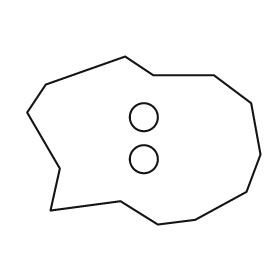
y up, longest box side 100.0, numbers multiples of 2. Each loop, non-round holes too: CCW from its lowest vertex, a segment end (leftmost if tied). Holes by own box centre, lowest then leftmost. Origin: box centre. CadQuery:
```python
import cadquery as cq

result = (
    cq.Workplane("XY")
    .moveTo(6.0, -36.0)
    .lineTo(22.0, -34.0)
    .lineTo(44.0, -22.0)
    .lineTo(50.0, -6.0)
    .lineTo(46.0, 16.0)
    .lineTo(30.0, 28.0)
    .lineTo(4.0, 28.0)
    .lineTo(-8.0, 36.0)
    .lineTo(-42.0, 24.0)
    .lineTo(-50.0, 12.0)
    .lineTo(-36.0, -12.0)
    .lineTo(-40.0, -30.0)
    .lineTo(-10.0, -26.0)
    .close()
    .moveTo(0.0, -8.0)
    .circle(6.0)
    .moveTo(0.0, 10.0)
    .circle(6.0)
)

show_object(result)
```